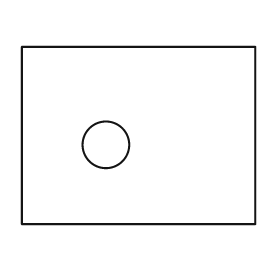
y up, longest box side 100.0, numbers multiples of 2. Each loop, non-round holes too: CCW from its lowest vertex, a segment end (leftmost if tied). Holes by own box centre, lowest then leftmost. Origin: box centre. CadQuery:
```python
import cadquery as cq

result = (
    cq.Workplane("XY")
    .moveTo(-50.0, -38.0)
    .lineTo(50.0, -38.0)
    .lineTo(50.0, 38.0)
    .lineTo(-50.0, 38.0)
    .close()
    .moveTo(-14.0, -4.0)
    .circle(10.0)
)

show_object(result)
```